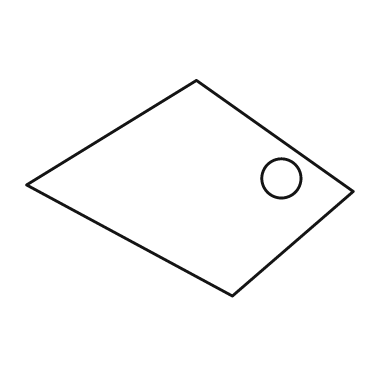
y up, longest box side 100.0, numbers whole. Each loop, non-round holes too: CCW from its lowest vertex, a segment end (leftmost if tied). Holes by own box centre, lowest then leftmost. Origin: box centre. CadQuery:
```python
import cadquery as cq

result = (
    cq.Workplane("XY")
    .moveTo(13.0, -33.0)
    .lineTo(50.0, -1.0)
    .lineTo(2.0, 33.0)
    .lineTo(-50.0, 1.0)
    .close()
    .moveTo(28.0, 3.0)
    .circle(6.0)
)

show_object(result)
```